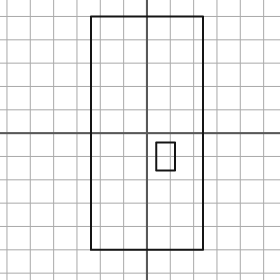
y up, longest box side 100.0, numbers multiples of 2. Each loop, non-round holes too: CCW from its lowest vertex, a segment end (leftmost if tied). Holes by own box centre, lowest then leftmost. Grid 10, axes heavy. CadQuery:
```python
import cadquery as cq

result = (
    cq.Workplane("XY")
    .moveTo(-24.0, -50.0)
    .lineTo(24.0, -50.0)
    .lineTo(24.0, 50.0)
    .lineTo(-24.0, 50.0)
    .close()
    .moveTo(4.0, -16.0)
    .lineTo(12.0, -16.0)
    .lineTo(12.0, -4.0)
    .lineTo(4.0, -4.0)
    .close()
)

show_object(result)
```